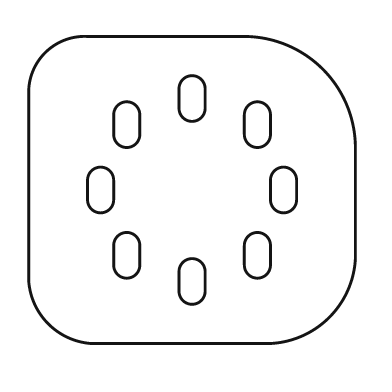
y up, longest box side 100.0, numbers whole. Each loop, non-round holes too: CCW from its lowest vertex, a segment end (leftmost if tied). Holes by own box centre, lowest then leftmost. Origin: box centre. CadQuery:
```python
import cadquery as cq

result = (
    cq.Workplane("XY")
    .moveTo(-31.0, -47.0)
    .lineTo(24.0, -47.0)
    .threePointArc((42.0, -39.0), (50.0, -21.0))
    .lineTo(50.0, 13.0)
    .threePointArc((40.0, 37.0), (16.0, 47.0))
    .lineTo(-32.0, 47.0)
    .threePointArc((-45.0, 42.0), (-50.0, 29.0))
    .lineTo(-50.0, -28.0)
    .threePointArc((-44.0, -41.0), (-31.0, -47.0))
    .close()
    .moveTo(-4.0, -31.0)
    .threePointArc((0.0, -35.0), (4.0, -31.0))
    .lineTo(4.0, -25.0)
    .threePointArc((0.0, -21.0), (-4.0, -25.0))
    .close()
    .moveTo(-24.0, -23.0)
    .threePointArc((-20.0, -27.0), (-16.0, -23.0))
    .lineTo(-16.0, -17.0)
    .threePointArc((-20.0, -13.0), (-24.0, -17.0))
    .close()
    .moveTo(16.0, -23.0)
    .threePointArc((20.0, -27.0), (24.0, -23.0))
    .lineTo(24.0, -17.0)
    .threePointArc((20.0, -13.0), (16.0, -17.0))
    .close()
    .moveTo(-32.0, -3.0)
    .threePointArc((-28.0, -7.0), (-24.0, -3.0))
    .lineTo(-24.0, 3.0)
    .threePointArc((-28.0, 7.0), (-32.0, 3.0))
    .close()
    .moveTo(24.0, -3.0)
    .threePointArc((28.0, -7.0), (32.0, -3.0))
    .lineTo(32.0, 3.0)
    .threePointArc((28.0, 7.0), (24.0, 3.0))
    .close()
    .moveTo(-24.0, 17.0)
    .threePointArc((-20.0, 13.0), (-16.0, 17.0))
    .lineTo(-16.0, 23.0)
    .threePointArc((-20.0, 27.0), (-24.0, 23.0))
    .close()
    .moveTo(16.0, 17.0)
    .threePointArc((20.0, 13.0), (24.0, 17.0))
    .lineTo(24.0, 23.0)
    .threePointArc((20.0, 27.0), (16.0, 23.0))
    .close()
    .moveTo(-4.0, 25.0)
    .threePointArc((0.0, 21.0), (4.0, 25.0))
    .lineTo(4.0, 31.0)
    .threePointArc((0.0, 35.0), (-4.0, 31.0))
    .close()
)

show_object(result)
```